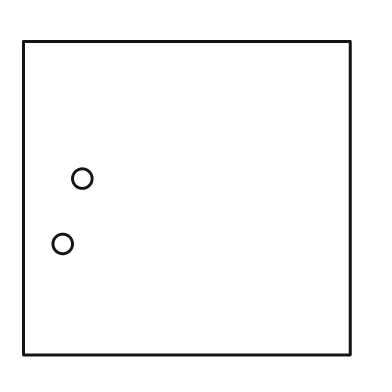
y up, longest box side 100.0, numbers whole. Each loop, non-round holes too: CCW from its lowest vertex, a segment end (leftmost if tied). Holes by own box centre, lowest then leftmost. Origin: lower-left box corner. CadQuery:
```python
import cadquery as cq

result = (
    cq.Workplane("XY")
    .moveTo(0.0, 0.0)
    .lineTo(100.0, 0.0)
    .lineTo(100.0, 96.0)
    .lineTo(0.0, 96.0)
    .close()
    .moveTo(12.0, 34.0)
    .circle(3.0)
    .moveTo(18.0, 54.0)
    .circle(3.0)
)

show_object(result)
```